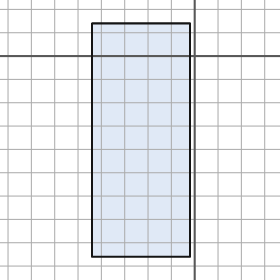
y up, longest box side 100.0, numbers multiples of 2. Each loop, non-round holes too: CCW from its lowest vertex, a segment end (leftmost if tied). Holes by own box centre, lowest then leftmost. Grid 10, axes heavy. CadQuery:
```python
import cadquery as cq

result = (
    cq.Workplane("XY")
    .moveTo(-44.0, -86.0)
    .lineTo(-2.0, -86.0)
    .lineTo(-2.0, 14.0)
    .lineTo(-44.0, 14.0)
    .close()
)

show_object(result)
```